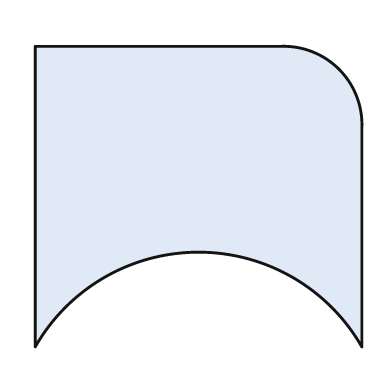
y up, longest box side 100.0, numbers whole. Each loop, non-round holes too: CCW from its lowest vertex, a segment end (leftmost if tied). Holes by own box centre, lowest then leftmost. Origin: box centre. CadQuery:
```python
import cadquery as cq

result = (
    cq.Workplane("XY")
    .moveTo(-50.0, -46.0)
    .threePointArc((0.0, -17.0), (50.0, -46.0))
    .lineTo(50.0, 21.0)
    .threePointArc((43.0, 39.0), (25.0, 46.0))
    .lineTo(-50.0, 46.0)
    .close()
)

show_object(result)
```